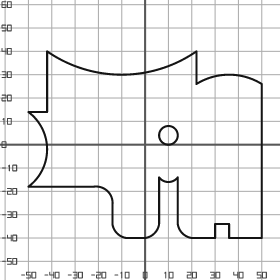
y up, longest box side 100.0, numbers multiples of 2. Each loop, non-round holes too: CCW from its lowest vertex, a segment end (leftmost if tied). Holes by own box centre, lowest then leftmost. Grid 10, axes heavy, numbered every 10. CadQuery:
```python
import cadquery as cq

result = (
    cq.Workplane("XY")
    .moveTo(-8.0, -40.0)
    .lineTo(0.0, -40.0)
    .threePointArc((4.0, -38.0), (6.0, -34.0))
    .lineTo(6.0, -14.0)
    .threePointArc((10.0, -16.0), (14.0, -14.0))
    .lineTo(14.0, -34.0)
    .threePointArc((16.0, -38.0), (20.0, -40.0))
    .lineTo(30.0, -40.0)
    .lineTo(30.0, -34.0)
    .lineTo(36.0, -34.0)
    .lineTo(36.0, -40.0)
    .lineTo(50.0, -40.0)
    .lineTo(50.0, 26.0)
    .threePointArc((36.0, 30.0), (22.0, 26.0))
    .lineTo(22.0, 40.0)
    .threePointArc((-10.0, 30.0), (-42.0, 40.0))
    .lineTo(-42.0, 14.0)
    .lineTo(-50.0, 14.0)
    .threePointArc((-42.0, -2.0), (-50.0, -18.0))
    .lineTo(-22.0, -18.0)
    .threePointArc((-16.0, -20.0), (-14.0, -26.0))
    .lineTo(-14.0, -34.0)
    .threePointArc((-12.0, -38.0), (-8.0, -40.0))
    .close()
    .moveTo(10.0, 4.0)
    .circle(4.0)
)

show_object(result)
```